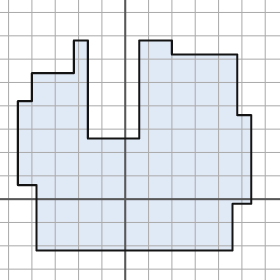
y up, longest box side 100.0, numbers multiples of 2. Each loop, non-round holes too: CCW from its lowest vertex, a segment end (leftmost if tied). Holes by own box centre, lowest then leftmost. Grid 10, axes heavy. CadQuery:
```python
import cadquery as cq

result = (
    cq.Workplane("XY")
    .moveTo(-38.0, -22.0)
    .lineTo(46.0, -22.0)
    .lineTo(46.0, -2.0)
    .lineTo(54.0, -2.0)
    .lineTo(54.0, 36.0)
    .lineTo(48.0, 36.0)
    .lineTo(48.0, 62.0)
    .lineTo(20.0, 62.0)
    .lineTo(20.0, 68.0)
    .lineTo(6.0, 68.0)
    .lineTo(6.0, 26.0)
    .lineTo(-16.0, 26.0)
    .lineTo(-16.0, 68.0)
    .lineTo(-22.0, 68.0)
    .lineTo(-22.0, 54.0)
    .lineTo(-40.0, 54.0)
    .lineTo(-40.0, 42.0)
    .lineTo(-46.0, 42.0)
    .lineTo(-46.0, 6.0)
    .lineTo(-38.0, 6.0)
    .close()
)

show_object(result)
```